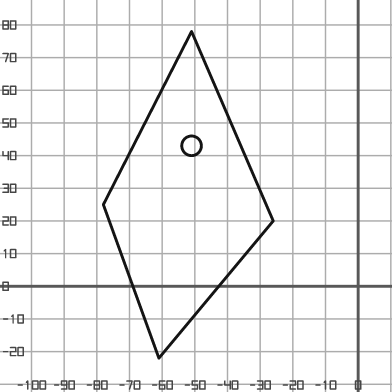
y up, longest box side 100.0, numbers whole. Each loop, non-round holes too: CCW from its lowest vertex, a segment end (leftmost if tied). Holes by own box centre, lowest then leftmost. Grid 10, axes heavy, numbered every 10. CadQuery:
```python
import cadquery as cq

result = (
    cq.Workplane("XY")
    .moveTo(-61.0, -22.0)
    .lineTo(-26.0, 20.0)
    .lineTo(-51.0, 78.0)
    .lineTo(-78.0, 25.0)
    .close()
    .moveTo(-51.0, 43.0)
    .circle(3.0)
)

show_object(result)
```